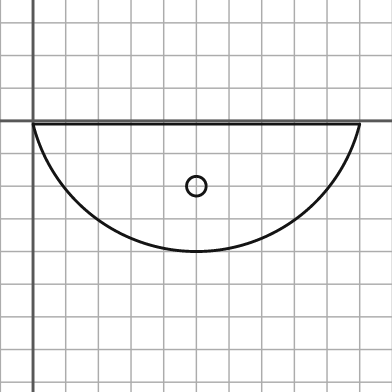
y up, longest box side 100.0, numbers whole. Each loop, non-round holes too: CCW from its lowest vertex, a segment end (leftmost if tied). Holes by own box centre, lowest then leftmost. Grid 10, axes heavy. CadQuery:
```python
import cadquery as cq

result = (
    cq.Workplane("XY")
    .moveTo(0.0, -1.0)
    .threePointArc((50.0, -40.0), (100.0, -1.0))
    .close()
    .moveTo(50.0, -20.0)
    .circle(3.0)
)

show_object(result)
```